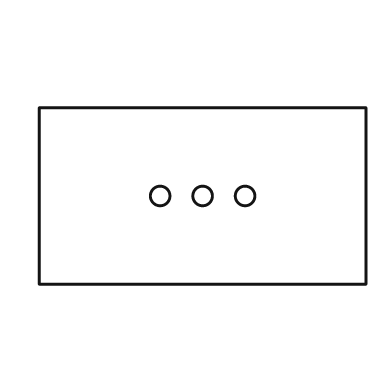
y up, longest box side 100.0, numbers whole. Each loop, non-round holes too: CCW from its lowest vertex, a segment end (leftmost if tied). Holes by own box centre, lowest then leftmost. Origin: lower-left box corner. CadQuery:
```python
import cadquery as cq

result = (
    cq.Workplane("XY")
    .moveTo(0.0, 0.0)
    .lineTo(100.0, 0.0)
    .lineTo(100.0, 54.0)
    .lineTo(0.0, 54.0)
    .close()
    .moveTo(37.0, 27.0)
    .circle(3.0)
    .moveTo(50.0, 27.0)
    .circle(3.0)
    .moveTo(63.0, 27.0)
    .circle(3.0)
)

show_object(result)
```